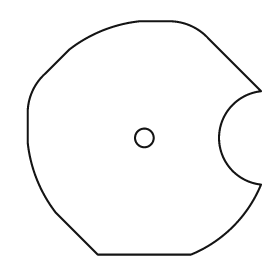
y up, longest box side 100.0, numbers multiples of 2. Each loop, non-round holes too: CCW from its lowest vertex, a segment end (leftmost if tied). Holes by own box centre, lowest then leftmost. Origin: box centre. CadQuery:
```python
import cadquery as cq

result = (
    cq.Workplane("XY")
    .moveTo(-20.0, -50.0)
    .lineTo(20.0, -50.0)
    .threePointArc((38.0, -38.0), (50.0, -20.0))
    .threePointArc((32.0, 0.0), (50.0, 20.0))
    .lineTo(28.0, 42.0)
    .threePointArc((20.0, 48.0), (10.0, 50.0))
    .lineTo(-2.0, 50.0)
    .threePointArc((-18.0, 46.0), (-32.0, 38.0))
    .lineTo(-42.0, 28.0)
    .threePointArc((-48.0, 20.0), (-50.0, 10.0))
    .lineTo(-50.0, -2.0)
    .threePointArc((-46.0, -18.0), (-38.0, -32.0))
    .close()
    .moveTo(0.0, 0.0)
    .circle(4.0)
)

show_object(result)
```